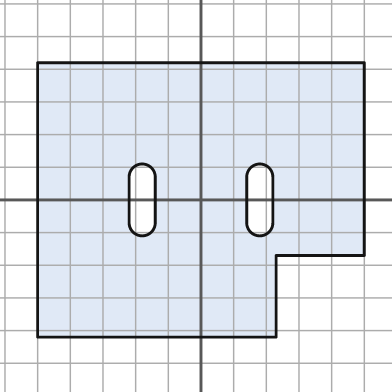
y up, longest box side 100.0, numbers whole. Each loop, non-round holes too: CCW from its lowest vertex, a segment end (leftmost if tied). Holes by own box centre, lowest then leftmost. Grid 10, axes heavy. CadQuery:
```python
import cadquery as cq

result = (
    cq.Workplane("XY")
    .moveTo(-50.0, -42.0)
    .lineTo(23.0, -42.0)
    .lineTo(23.0, -17.0)
    .lineTo(50.0, -17.0)
    .lineTo(50.0, 42.0)
    .lineTo(-50.0, 42.0)
    .close()
    .moveTo(-22.0, -7.0)
    .threePointArc((-18.0, -11.0), (-14.0, -7.0))
    .lineTo(-14.0, 7.0)
    .threePointArc((-18.0, 11.0), (-22.0, 7.0))
    .close()
    .moveTo(14.0, -7.0)
    .threePointArc((18.0, -11.0), (22.0, -7.0))
    .lineTo(22.0, 7.0)
    .threePointArc((18.0, 11.0), (14.0, 7.0))
    .close()
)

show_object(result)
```